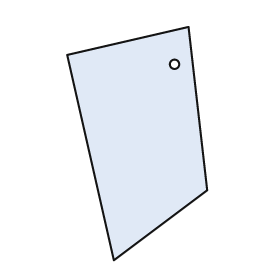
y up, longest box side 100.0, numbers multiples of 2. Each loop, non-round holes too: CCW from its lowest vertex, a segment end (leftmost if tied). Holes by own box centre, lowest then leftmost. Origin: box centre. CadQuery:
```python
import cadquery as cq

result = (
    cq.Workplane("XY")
    .moveTo(-10.0, -50.0)
    .lineTo(30.0, -20.0)
    .lineTo(22.0, 50.0)
    .lineTo(-30.0, 38.0)
    .close()
    .moveTo(16.0, 34.0)
    .circle(2.0)
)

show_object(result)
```